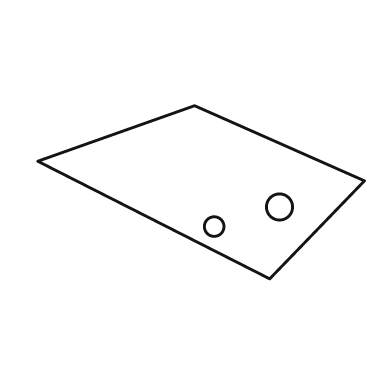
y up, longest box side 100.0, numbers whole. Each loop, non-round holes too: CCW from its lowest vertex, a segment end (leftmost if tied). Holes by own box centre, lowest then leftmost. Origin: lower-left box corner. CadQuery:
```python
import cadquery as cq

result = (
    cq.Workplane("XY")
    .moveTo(71.0, 0.0)
    .lineTo(100.0, 30.0)
    .lineTo(48.0, 53.0)
    .lineTo(0.0, 36.0)
    .close()
    .moveTo(54.0, 16.0)
    .circle(3.0)
    .moveTo(74.0, 22.0)
    .circle(4.0)
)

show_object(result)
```